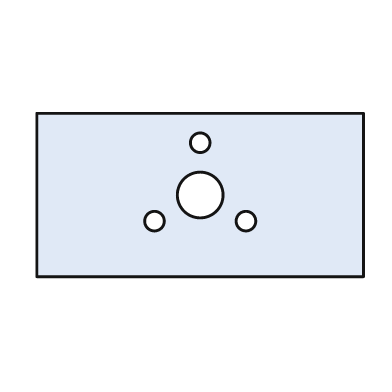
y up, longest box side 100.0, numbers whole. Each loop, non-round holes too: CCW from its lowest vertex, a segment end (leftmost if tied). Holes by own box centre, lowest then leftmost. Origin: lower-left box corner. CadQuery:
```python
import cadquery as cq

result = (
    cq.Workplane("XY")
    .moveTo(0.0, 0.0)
    .lineTo(100.0, 0.0)
    .lineTo(100.0, 50.0)
    .lineTo(0.0, 50.0)
    .close()
    .moveTo(36.0, 17.0)
    .circle(3.0)
    .moveTo(64.0, 17.0)
    .circle(3.0)
    .moveTo(50.0, 25.0)
    .circle(7.0)
    .moveTo(50.0, 41.0)
    .circle(3.0)
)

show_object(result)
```